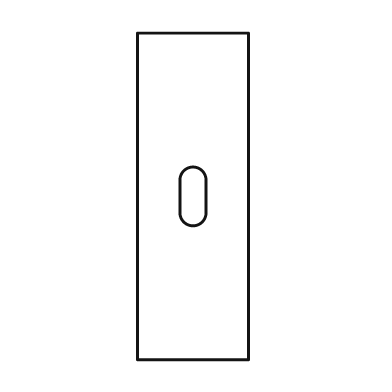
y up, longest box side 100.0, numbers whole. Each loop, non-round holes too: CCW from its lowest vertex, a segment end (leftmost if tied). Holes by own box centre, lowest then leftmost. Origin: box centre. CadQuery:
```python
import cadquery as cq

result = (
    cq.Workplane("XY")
    .moveTo(-17.0, -50.0)
    .lineTo(17.0, -50.0)
    .lineTo(17.0, 50.0)
    .lineTo(-17.0, 50.0)
    .close()
    .moveTo(-4.0, -5.0)
    .threePointArc((0.0, -9.0), (4.0, -5.0))
    .lineTo(4.0, 5.0)
    .threePointArc((0.0, 9.0), (-4.0, 5.0))
    .close()
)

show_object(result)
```